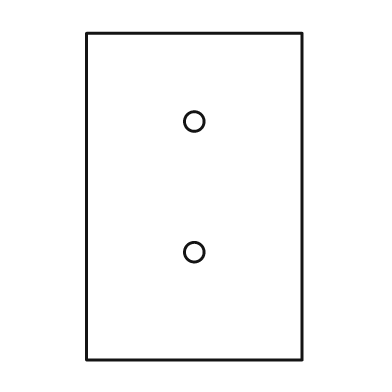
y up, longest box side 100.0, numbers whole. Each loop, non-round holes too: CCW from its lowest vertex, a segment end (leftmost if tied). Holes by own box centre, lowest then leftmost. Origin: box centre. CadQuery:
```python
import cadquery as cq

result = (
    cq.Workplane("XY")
    .moveTo(-33.0, -50.0)
    .lineTo(33.0, -50.0)
    .lineTo(33.0, 50.0)
    .lineTo(-33.0, 50.0)
    .close()
    .moveTo(0.0, -17.0)
    .circle(3.0)
    .moveTo(0.0, 23.0)
    .circle(3.0)
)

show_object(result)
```